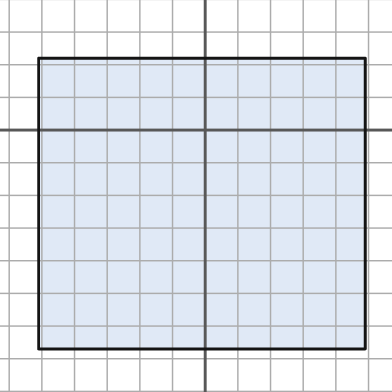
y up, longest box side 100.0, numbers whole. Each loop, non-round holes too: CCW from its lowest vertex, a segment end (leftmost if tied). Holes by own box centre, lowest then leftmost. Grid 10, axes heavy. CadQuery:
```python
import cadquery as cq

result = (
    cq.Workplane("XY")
    .moveTo(-51.0, -67.0)
    .lineTo(49.0, -67.0)
    .lineTo(49.0, 22.0)
    .lineTo(-51.0, 22.0)
    .close()
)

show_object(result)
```